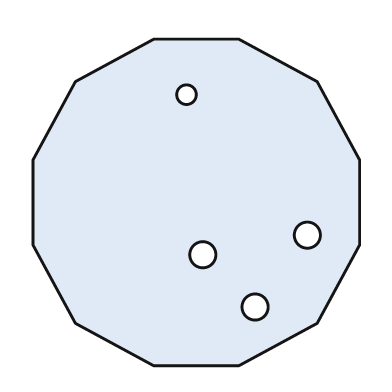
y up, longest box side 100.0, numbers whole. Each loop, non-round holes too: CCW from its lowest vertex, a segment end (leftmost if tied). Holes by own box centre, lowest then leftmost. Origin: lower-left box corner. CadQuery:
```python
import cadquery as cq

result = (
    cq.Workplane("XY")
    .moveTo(37.0, 0.0)
    .lineTo(63.0, 0.0)
    .lineTo(87.0, 13.0)
    .lineTo(100.0, 37.0)
    .lineTo(100.0, 63.0)
    .lineTo(87.0, 87.0)
    .lineTo(63.0, 100.0)
    .lineTo(37.0, 100.0)
    .lineTo(13.0, 87.0)
    .lineTo(0.0, 63.0)
    .lineTo(0.0, 37.0)
    .lineTo(13.0, 13.0)
    .close()
    .moveTo(68.0, 18.0)
    .circle(4.0)
    .moveTo(52.0, 34.0)
    .circle(4.0)
    .moveTo(84.0, 40.0)
    .circle(4.0)
    .moveTo(47.0, 83.0)
    .circle(3.0)
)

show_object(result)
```